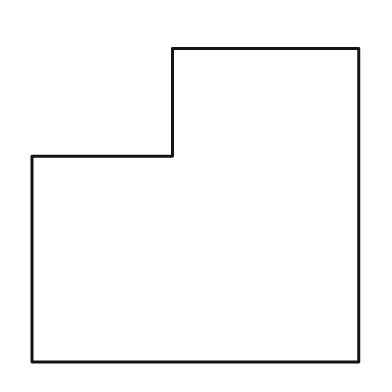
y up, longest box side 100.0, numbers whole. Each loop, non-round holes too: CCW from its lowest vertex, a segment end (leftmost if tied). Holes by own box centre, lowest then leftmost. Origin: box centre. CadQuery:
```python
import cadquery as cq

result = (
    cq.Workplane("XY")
    .moveTo(-50.0, -48.0)
    .lineTo(50.0, -48.0)
    .lineTo(50.0, 48.0)
    .lineTo(-7.0, 48.0)
    .lineTo(-7.0, 15.0)
    .lineTo(-50.0, 15.0)
    .close()
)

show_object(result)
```